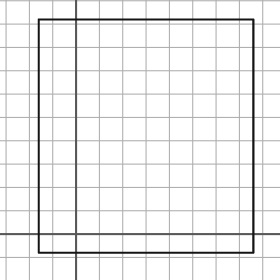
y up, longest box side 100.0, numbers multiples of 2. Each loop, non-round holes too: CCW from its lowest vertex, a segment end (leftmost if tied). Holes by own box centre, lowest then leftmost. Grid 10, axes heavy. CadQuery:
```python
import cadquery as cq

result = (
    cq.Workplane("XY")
    .moveTo(-16.0, -8.0)
    .lineTo(76.0, -8.0)
    .lineTo(76.0, 92.0)
    .lineTo(-16.0, 92.0)
    .close()
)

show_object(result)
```